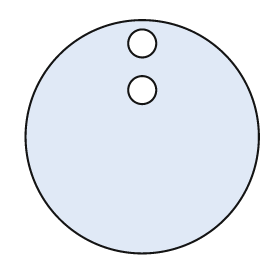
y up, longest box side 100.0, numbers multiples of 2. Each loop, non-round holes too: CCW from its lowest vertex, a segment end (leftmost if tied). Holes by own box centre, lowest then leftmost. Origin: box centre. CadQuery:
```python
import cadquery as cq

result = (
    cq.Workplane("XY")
    .moveTo(0.0, 0.0)
    .circle(50.0)
    .moveTo(0.0, 20.0)
    .circle(6.0)
    .moveTo(0.0, 40.0)
    .circle(6.0)
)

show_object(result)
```